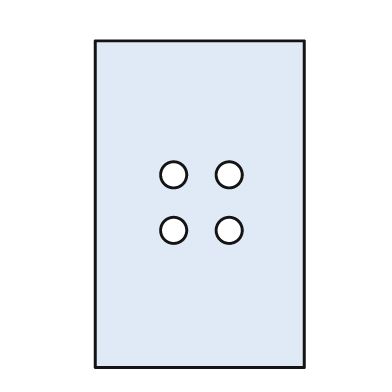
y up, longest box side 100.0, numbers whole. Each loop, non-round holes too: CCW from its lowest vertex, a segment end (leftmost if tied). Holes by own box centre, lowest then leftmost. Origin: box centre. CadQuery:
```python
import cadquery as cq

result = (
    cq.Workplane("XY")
    .moveTo(-32.0, -50.0)
    .lineTo(32.0, -50.0)
    .lineTo(32.0, 50.0)
    .lineTo(-32.0, 50.0)
    .close()
    .moveTo(-8.0, -8.0)
    .circle(4.0)
    .moveTo(9.0, -8.0)
    .circle(4.0)
    .moveTo(-8.0, 9.0)
    .circle(4.0)
    .moveTo(9.0, 9.0)
    .circle(4.0)
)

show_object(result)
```